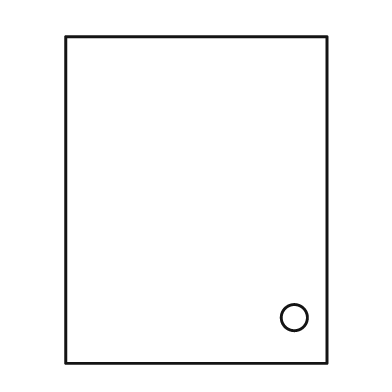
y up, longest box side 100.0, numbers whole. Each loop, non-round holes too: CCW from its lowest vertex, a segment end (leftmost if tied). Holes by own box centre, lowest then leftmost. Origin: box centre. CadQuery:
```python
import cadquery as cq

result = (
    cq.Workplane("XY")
    .moveTo(-40.0, -50.0)
    .lineTo(40.0, -50.0)
    .lineTo(40.0, 50.0)
    .lineTo(-40.0, 50.0)
    .close()
    .moveTo(30.0, -36.0)
    .circle(4.0)
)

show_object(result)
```